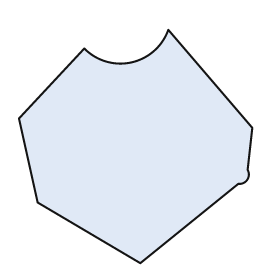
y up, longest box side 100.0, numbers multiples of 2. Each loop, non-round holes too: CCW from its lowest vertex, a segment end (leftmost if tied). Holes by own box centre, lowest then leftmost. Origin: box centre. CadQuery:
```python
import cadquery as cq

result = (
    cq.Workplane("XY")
    .moveTo(2.0, -50.0)
    .lineTo(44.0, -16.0)
    .threePointArc((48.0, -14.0), (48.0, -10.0))
    .lineTo(50.0, 8.0)
    .lineTo(14.0, 50.0)
    .threePointArc((-2.0, 36.0), (-22.0, 42.0))
    .lineTo(-50.0, 12.0)
    .lineTo(-42.0, -24.0)
    .close()
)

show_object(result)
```